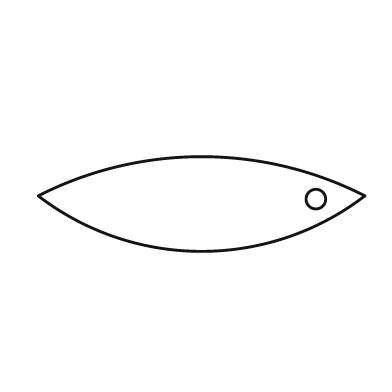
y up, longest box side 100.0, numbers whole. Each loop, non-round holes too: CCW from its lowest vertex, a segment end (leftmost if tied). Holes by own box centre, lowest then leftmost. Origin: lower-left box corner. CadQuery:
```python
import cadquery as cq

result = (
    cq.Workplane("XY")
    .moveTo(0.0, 17.0)
    .threePointArc((50.0, 0.0), (100.0, 17.0))
    .threePointArc((50.0, 29.0), (0.0, 17.0))
    .close()
    .moveTo(85.0, 16.0)
    .circle(3.0)
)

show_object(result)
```